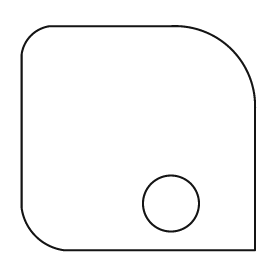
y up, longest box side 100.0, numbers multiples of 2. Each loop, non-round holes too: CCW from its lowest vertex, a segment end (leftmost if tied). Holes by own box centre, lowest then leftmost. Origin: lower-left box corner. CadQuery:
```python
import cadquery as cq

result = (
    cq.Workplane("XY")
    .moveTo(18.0, 0.0)
    .lineTo(100.0, 0.0)
    .lineTo(100.0, 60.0)
    .threePointArc((90.0, 86.0), (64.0, 96.0))
    .lineTo(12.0, 96.0)
    .threePointArc((4.0, 92.0), (0.0, 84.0))
    .lineTo(0.0, 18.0)
    .threePointArc((6.0, 6.0), (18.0, 0.0))
    .close()
    .moveTo(64.0, 20.0)
    .circle(12.0)
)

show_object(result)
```